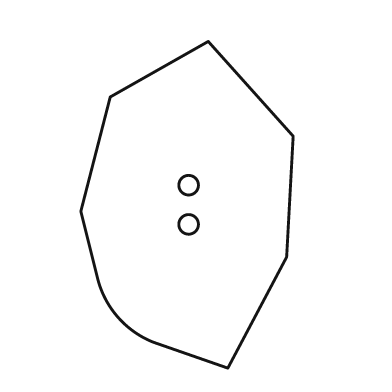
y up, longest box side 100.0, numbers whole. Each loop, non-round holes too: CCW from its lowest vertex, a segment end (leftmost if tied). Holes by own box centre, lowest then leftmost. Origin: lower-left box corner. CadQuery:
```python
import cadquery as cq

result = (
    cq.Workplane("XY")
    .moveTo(45.0, 0.0)
    .lineTo(63.0, 34.0)
    .lineTo(65.0, 71.0)
    .lineTo(39.0, 100.0)
    .lineTo(9.0, 83.0)
    .lineTo(0.0, 48.0)
    .lineTo(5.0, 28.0)
    .threePointArc((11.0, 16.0), (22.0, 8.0))
    .close()
    .moveTo(33.0, 44.0)
    .circle(3.0)
    .moveTo(33.0, 56.0)
    .circle(3.0)
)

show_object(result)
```